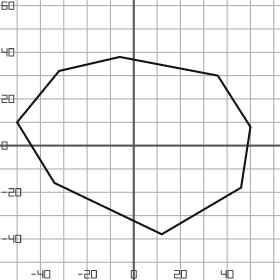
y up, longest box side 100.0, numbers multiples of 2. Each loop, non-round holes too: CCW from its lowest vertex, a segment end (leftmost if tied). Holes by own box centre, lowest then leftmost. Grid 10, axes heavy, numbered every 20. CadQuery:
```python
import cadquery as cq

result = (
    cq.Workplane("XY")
    .moveTo(12.0, -38.0)
    .lineTo(46.0, -18.0)
    .lineTo(50.0, 8.0)
    .lineTo(36.0, 30.0)
    .lineTo(-6.0, 38.0)
    .lineTo(-32.0, 32.0)
    .lineTo(-50.0, 10.0)
    .lineTo(-34.0, -16.0)
    .close()
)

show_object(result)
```